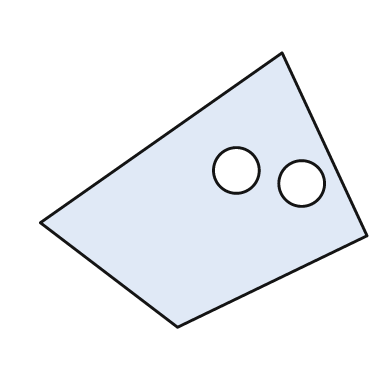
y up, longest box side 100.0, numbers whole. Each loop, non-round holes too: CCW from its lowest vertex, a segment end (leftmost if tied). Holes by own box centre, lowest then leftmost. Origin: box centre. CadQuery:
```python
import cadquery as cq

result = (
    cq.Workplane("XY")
    .moveTo(-8.0, -42.0)
    .lineTo(50.0, -14.0)
    .lineTo(24.0, 42.0)
    .lineTo(-50.0, -10.0)
    .close()
    .moveTo(30.0, 2.0)
    .circle(7.0)
    .moveTo(10.0, 6.0)
    .circle(7.0)
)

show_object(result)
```